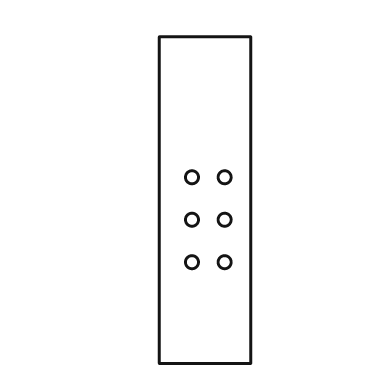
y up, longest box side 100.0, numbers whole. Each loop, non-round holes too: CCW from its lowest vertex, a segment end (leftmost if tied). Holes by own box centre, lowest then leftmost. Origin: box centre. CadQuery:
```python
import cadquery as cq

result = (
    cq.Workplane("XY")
    .moveTo(-14.0, -50.0)
    .lineTo(14.0, -50.0)
    .lineTo(14.0, 50.0)
    .lineTo(-14.0, 50.0)
    .close()
    .moveTo(-4.0, -19.0)
    .circle(2.0)
    .moveTo(6.0, -19.0)
    .circle(2.0)
    .moveTo(-4.0, -6.0)
    .circle(2.0)
    .moveTo(6.0, -6.0)
    .circle(2.0)
    .moveTo(-4.0, 7.0)
    .circle(2.0)
    .moveTo(6.0, 7.0)
    .circle(2.0)
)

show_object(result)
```